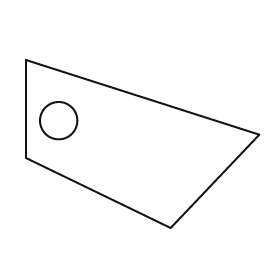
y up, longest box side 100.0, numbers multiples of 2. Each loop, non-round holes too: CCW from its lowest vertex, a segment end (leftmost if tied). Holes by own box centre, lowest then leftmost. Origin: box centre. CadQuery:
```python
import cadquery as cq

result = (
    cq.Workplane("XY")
    .moveTo(12.0, -36.0)
    .lineTo(50.0, 4.0)
    .lineTo(-50.0, 36.0)
    .lineTo(-50.0, -6.0)
    .close()
    .moveTo(-36.0, 10.0)
    .circle(8.0)
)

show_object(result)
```